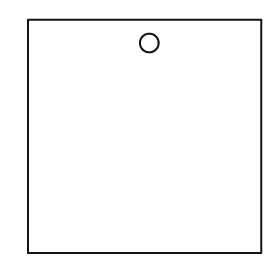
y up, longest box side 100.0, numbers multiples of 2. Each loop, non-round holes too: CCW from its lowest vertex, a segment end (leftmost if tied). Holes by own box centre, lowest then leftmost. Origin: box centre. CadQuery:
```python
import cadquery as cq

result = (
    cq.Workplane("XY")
    .moveTo(-50.0, -50.0)
    .lineTo(50.0, -50.0)
    .lineTo(50.0, 50.0)
    .lineTo(-50.0, 50.0)
    .close()
    .moveTo(2.0, 40.0)
    .circle(4.0)
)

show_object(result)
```